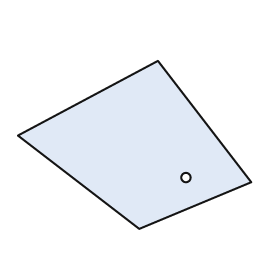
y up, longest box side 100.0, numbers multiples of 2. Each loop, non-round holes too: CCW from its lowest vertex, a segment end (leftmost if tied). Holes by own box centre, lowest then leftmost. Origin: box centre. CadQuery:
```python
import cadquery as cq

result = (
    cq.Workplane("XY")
    .moveTo(2.0, -36.0)
    .lineTo(50.0, -16.0)
    .lineTo(10.0, 36.0)
    .lineTo(-50.0, 4.0)
    .close()
    .moveTo(22.0, -14.0)
    .circle(2.0)
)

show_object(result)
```